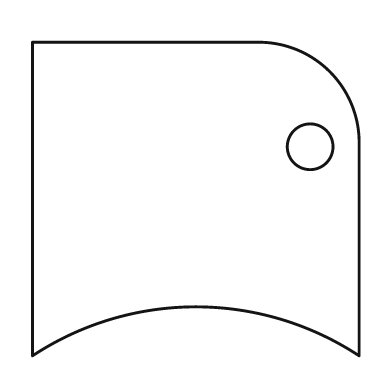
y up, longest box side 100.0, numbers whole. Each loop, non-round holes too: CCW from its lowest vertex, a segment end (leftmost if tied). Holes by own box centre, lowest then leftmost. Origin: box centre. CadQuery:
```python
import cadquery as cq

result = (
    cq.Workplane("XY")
    .moveTo(-50.0, -48.0)
    .threePointArc((0.0, -33.0), (50.0, -48.0))
    .lineTo(50.0, 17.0)
    .threePointArc((41.0, 39.0), (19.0, 48.0))
    .lineTo(-50.0, 48.0)
    .close()
    .moveTo(35.0, 16.0)
    .circle(7.0)
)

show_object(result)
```